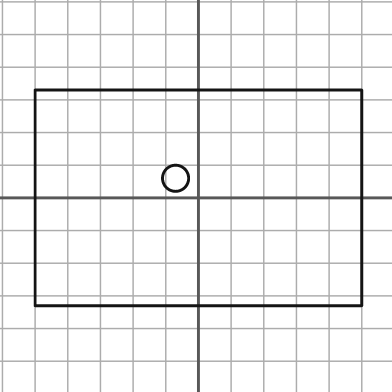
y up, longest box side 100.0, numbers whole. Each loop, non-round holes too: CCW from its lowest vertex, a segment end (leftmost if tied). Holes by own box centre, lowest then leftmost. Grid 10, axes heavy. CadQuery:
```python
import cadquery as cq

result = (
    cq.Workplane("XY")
    .moveTo(-50.0, -33.0)
    .lineTo(50.0, -33.0)
    .lineTo(50.0, 33.0)
    .lineTo(-50.0, 33.0)
    .close()
    .moveTo(-7.0, 6.0)
    .circle(4.0)
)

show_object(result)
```